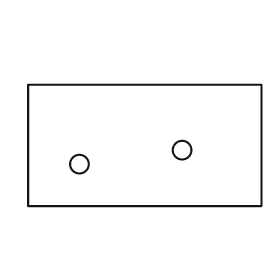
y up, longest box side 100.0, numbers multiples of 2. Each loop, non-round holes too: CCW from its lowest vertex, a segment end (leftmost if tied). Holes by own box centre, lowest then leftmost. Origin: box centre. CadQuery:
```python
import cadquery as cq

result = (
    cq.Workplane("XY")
    .moveTo(-50.0, -26.0)
    .lineTo(50.0, -26.0)
    .lineTo(50.0, 26.0)
    .lineTo(-50.0, 26.0)
    .close()
    .moveTo(-28.0, -8.0)
    .circle(4.0)
    .moveTo(16.0, -2.0)
    .circle(4.0)
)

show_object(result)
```